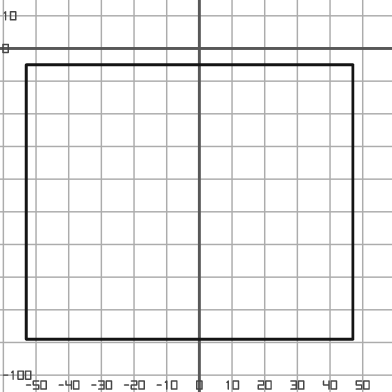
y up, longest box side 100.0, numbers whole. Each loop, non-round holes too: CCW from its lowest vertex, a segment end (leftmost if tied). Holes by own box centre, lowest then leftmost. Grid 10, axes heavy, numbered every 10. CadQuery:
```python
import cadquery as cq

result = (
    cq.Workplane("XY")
    .moveTo(-53.0, -89.0)
    .lineTo(47.0, -89.0)
    .lineTo(47.0, -5.0)
    .lineTo(-53.0, -5.0)
    .close()
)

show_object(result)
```